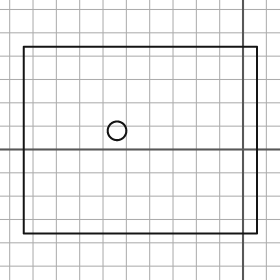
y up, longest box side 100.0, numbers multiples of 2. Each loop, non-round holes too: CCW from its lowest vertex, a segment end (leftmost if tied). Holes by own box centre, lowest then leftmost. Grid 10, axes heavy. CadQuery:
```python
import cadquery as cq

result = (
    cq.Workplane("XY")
    .moveTo(-94.0, -36.0)
    .lineTo(6.0, -36.0)
    .lineTo(6.0, 44.0)
    .lineTo(-94.0, 44.0)
    .close()
    .moveTo(-54.0, 8.0)
    .circle(4.0)
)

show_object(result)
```